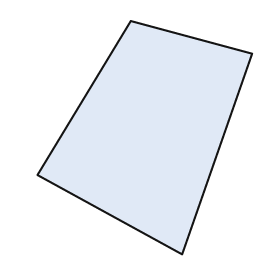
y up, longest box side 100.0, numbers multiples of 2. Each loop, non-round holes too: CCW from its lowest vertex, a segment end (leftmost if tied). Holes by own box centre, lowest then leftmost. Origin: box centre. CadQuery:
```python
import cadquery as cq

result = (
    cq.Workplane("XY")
    .moveTo(16.0, -50.0)
    .lineTo(46.0, 36.0)
    .lineTo(-6.0, 50.0)
    .lineTo(-46.0, -16.0)
    .close()
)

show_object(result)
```